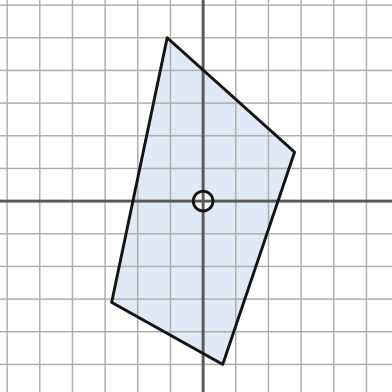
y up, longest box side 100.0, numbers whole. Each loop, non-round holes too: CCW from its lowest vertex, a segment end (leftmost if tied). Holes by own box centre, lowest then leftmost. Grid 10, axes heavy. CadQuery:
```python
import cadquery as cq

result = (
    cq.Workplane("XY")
    .moveTo(6.0, -50.0)
    .lineTo(28.0, 15.0)
    .lineTo(-11.0, 50.0)
    .lineTo(-28.0, -31.0)
    .close()
    .moveTo(0.0, 0.0)
    .circle(3.0)
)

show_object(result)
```